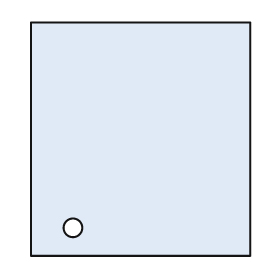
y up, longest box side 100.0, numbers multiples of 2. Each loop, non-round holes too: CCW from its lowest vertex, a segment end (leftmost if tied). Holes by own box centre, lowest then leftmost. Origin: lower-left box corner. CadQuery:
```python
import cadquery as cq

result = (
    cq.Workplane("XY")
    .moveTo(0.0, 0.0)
    .lineTo(94.0, 0.0)
    .lineTo(94.0, 100.0)
    .lineTo(0.0, 100.0)
    .close()
    .moveTo(18.0, 12.0)
    .circle(4.0)
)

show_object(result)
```